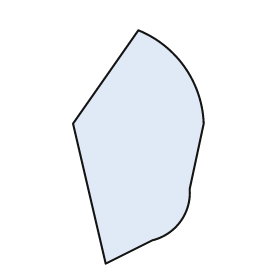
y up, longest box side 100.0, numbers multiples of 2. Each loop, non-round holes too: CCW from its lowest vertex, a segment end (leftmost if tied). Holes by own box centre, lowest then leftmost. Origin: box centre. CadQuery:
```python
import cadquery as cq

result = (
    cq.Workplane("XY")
    .moveTo(-14.0, -50.0)
    .lineTo(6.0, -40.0)
    .threePointArc((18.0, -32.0), (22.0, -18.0))
    .lineTo(28.0, 10.0)
    .threePointArc((20.0, 34.0), (0.0, 50.0))
    .lineTo(-28.0, 10.0)
    .close()
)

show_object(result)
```